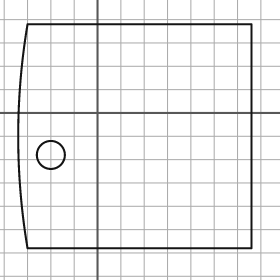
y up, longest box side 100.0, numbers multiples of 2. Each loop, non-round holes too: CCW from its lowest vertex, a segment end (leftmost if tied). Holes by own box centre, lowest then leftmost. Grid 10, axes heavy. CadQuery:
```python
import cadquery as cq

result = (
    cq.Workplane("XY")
    .moveTo(-30.0, -58.0)
    .lineTo(66.0, -58.0)
    .lineTo(66.0, 38.0)
    .lineTo(-30.0, 38.0)
    .threePointArc((-34.0, -10.0), (-30.0, -58.0))
    .close()
    .moveTo(-20.0, -18.0)
    .circle(6.0)
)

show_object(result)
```